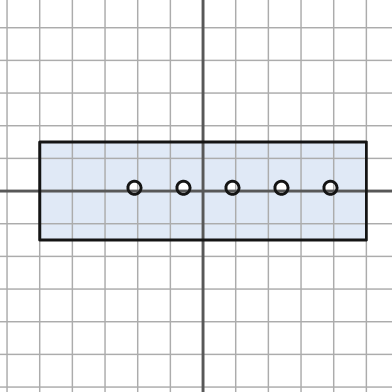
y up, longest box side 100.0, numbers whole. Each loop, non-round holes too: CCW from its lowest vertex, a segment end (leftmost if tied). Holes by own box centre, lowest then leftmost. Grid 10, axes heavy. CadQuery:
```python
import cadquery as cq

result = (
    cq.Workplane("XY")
    .moveTo(-50.0, -15.0)
    .lineTo(50.0, -15.0)
    .lineTo(50.0, 15.0)
    .lineTo(-50.0, 15.0)
    .close()
    .moveTo(-21.0, 1.0)
    .circle(2.0)
    .moveTo(-6.0, 1.0)
    .circle(2.0)
    .moveTo(9.0, 1.0)
    .circle(2.0)
    .moveTo(24.0, 1.0)
    .circle(2.0)
    .moveTo(39.0, 1.0)
    .circle(2.0)
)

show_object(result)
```